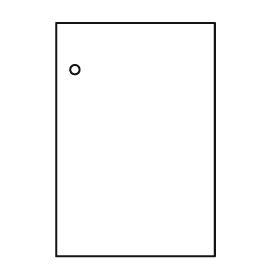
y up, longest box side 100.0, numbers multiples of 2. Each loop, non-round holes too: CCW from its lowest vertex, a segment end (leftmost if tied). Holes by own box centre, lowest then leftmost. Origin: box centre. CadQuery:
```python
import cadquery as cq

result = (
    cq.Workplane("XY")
    .moveTo(-34.0, -50.0)
    .lineTo(34.0, -50.0)
    .lineTo(34.0, 50.0)
    .lineTo(-34.0, 50.0)
    .close()
    .moveTo(-26.0, 30.0)
    .circle(2.0)
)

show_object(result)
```